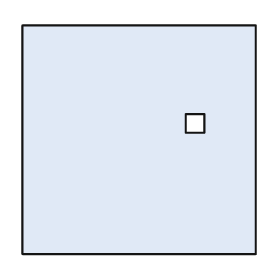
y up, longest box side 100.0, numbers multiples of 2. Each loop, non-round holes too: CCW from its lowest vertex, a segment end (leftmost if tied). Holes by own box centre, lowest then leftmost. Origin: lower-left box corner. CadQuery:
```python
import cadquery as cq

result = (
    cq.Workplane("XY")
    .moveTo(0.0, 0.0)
    .lineTo(100.0, 0.0)
    .lineTo(100.0, 98.0)
    .lineTo(0.0, 98.0)
    .close()
    .moveTo(70.0, 52.0)
    .lineTo(78.0, 52.0)
    .lineTo(78.0, 60.0)
    .lineTo(70.0, 60.0)
    .close()
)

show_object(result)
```